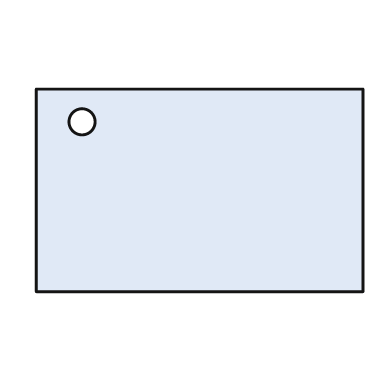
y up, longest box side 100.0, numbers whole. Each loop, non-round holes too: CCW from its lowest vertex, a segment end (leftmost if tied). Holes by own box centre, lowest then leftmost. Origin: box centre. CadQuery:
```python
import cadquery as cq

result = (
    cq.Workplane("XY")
    .moveTo(-50.0, -31.0)
    .lineTo(50.0, -31.0)
    .lineTo(50.0, 31.0)
    .lineTo(-50.0, 31.0)
    .close()
    .moveTo(-36.0, 21.0)
    .circle(4.0)
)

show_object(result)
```